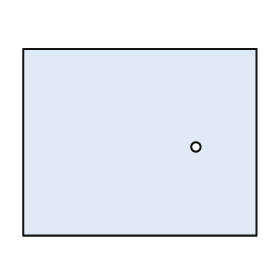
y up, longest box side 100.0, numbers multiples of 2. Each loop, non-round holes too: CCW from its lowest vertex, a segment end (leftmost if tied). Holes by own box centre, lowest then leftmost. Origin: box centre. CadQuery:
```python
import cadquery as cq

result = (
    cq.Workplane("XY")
    .moveTo(-50.0, -40.0)
    .lineTo(50.0, -40.0)
    .lineTo(50.0, 40.0)
    .lineTo(-50.0, 40.0)
    .close()
    .moveTo(24.0, -2.0)
    .circle(2.0)
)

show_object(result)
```